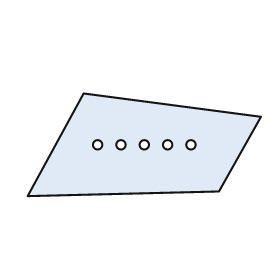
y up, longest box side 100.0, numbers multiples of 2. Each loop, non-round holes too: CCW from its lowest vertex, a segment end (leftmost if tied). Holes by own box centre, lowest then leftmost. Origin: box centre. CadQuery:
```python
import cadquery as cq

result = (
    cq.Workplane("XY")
    .moveTo(-50.0, -22.0)
    .lineTo(32.0, -20.0)
    .lineTo(50.0, 12.0)
    .lineTo(-26.0, 22.0)
    .close()
    .moveTo(-20.0, 0.0)
    .circle(2.0)
    .moveTo(-10.0, 0.0)
    .circle(2.0)
    .moveTo(0.0, 0.0)
    .circle(2.0)
    .moveTo(10.0, 0.0)
    .circle(2.0)
    .moveTo(20.0, 0.0)
    .circle(2.0)
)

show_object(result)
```